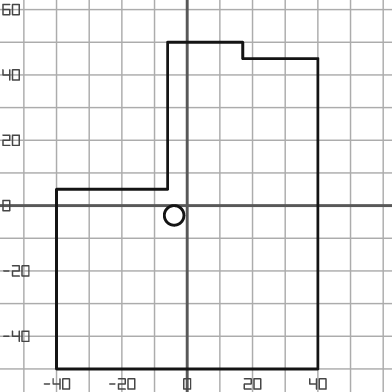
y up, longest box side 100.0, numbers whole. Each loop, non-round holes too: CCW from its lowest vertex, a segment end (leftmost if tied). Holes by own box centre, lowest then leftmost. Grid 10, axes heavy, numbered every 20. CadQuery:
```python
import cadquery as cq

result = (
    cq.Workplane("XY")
    .moveTo(-40.0, -50.0)
    .lineTo(40.0, -50.0)
    .lineTo(40.0, 45.0)
    .lineTo(17.0, 45.0)
    .lineTo(17.0, 50.0)
    .lineTo(-6.0, 50.0)
    .lineTo(-6.0, 5.0)
    .lineTo(-40.0, 5.0)
    .close()
    .moveTo(-4.0, -3.0)
    .circle(3.0)
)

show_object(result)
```